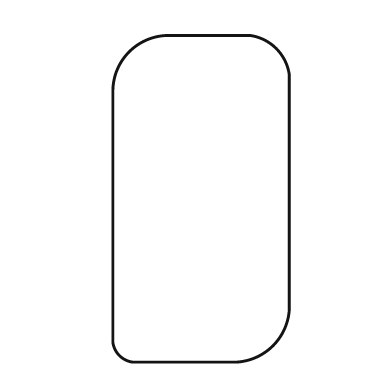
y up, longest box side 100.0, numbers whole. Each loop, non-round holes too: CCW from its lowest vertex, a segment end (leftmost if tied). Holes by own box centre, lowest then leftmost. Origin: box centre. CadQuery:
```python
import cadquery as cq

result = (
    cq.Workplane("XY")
    .moveTo(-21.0, -50.0)
    .lineTo(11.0, -50.0)
    .threePointArc((22.0, -45.0), (27.0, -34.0))
    .lineTo(27.0, 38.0)
    .threePointArc((23.0, 46.0), (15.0, 50.0))
    .lineTo(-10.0, 50.0)
    .threePointArc((-22.0, 45.0), (-27.0, 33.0))
    .lineTo(-27.0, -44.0)
    .threePointArc((-25.0, -48.0), (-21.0, -50.0))
    .close()
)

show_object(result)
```